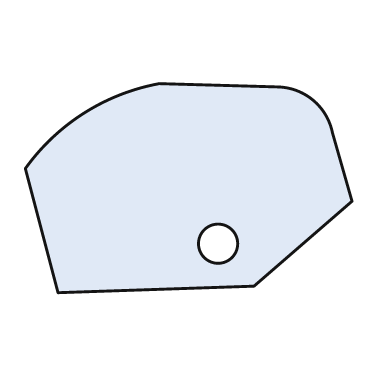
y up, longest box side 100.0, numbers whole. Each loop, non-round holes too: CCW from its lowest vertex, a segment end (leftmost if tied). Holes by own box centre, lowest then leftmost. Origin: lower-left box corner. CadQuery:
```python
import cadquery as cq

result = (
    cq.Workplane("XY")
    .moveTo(10.0, 0.0)
    .lineTo(70.0, 2.0)
    .lineTo(100.0, 28.0)
    .lineTo(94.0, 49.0)
    .threePointArc((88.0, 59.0), (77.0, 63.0))
    .lineTo(41.0, 64.0)
    .threePointArc((18.0, 55.0), (0.0, 38.0))
    .close()
    .moveTo(59.0, 15.0)
    .circle(6.0)
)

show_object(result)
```